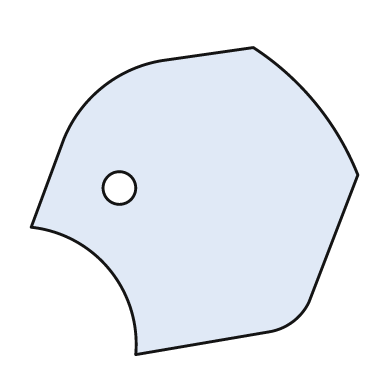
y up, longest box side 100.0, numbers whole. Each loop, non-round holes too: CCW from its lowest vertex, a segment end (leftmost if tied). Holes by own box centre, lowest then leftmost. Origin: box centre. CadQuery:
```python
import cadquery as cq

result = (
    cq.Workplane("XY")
    .moveTo(-18.0, -47.0)
    .lineTo(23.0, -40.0)
    .threePointArc((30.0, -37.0), (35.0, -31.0))
    .lineTo(50.0, 8.0)
    .threePointArc((37.0, 30.0), (18.0, 47.0))
    .lineTo(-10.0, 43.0)
    .threePointArc((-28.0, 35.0), (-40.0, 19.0))
    .lineTo(-50.0, -8.0)
    .threePointArc((-26.0, -21.0), (-18.0, -47.0))
    .close()
    .moveTo(-23.0, 4.0)
    .circle(5.0)
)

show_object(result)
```